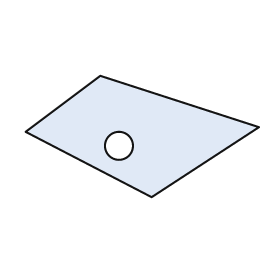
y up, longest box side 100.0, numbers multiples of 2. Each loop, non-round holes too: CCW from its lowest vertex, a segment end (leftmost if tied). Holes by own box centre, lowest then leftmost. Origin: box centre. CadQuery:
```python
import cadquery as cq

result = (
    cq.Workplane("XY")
    .moveTo(4.0, -26.0)
    .lineTo(50.0, 4.0)
    .lineTo(-18.0, 26.0)
    .lineTo(-50.0, 2.0)
    .close()
    .moveTo(-10.0, -4.0)
    .circle(6.0)
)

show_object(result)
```